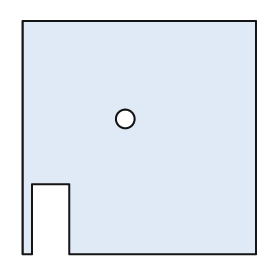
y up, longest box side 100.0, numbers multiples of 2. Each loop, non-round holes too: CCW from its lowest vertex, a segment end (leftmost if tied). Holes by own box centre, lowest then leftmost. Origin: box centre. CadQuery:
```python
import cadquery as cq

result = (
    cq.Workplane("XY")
    .moveTo(-50.0, -50.0)
    .lineTo(-46.0, -50.0)
    .lineTo(-46.0, -20.0)
    .lineTo(-30.0, -20.0)
    .lineTo(-30.0, -50.0)
    .lineTo(50.0, -50.0)
    .lineTo(50.0, 50.0)
    .lineTo(-50.0, 50.0)
    .close()
    .moveTo(-6.0, 8.0)
    .circle(4.0)
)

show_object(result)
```